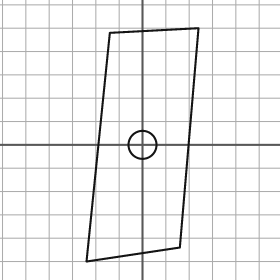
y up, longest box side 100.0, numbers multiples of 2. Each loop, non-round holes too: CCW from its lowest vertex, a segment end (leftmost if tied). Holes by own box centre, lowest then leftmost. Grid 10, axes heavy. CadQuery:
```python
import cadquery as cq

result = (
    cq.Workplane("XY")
    .moveTo(-24.0, -50.0)
    .lineTo(16.0, -44.0)
    .lineTo(24.0, 50.0)
    .lineTo(-14.0, 48.0)
    .close()
    .moveTo(0.0, 0.0)
    .circle(6.0)
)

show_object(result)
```